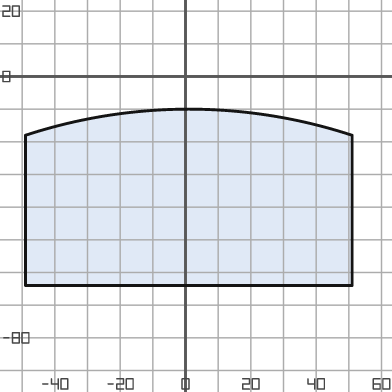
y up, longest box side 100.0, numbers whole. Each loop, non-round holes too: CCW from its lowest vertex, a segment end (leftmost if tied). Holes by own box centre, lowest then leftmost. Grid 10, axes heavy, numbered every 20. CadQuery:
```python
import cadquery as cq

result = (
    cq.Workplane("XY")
    .moveTo(-49.0, -64.0)
    .lineTo(51.0, -64.0)
    .lineTo(51.0, -18.0)
    .threePointArc((1.0, -10.0), (-49.0, -18.0))
    .close()
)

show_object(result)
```